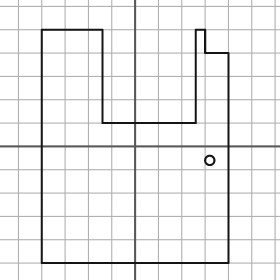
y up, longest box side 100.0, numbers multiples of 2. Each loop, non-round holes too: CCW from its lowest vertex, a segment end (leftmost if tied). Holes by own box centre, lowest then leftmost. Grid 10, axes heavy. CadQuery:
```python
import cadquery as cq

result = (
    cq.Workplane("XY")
    .moveTo(-40.0, -50.0)
    .lineTo(40.0, -50.0)
    .lineTo(40.0, 40.0)
    .lineTo(30.0, 40.0)
    .lineTo(30.0, 50.0)
    .lineTo(26.0, 50.0)
    .lineTo(26.0, 10.0)
    .lineTo(-14.0, 10.0)
    .lineTo(-14.0, 50.0)
    .lineTo(-40.0, 50.0)
    .close()
    .moveTo(32.0, -6.0)
    .circle(2.0)
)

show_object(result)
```